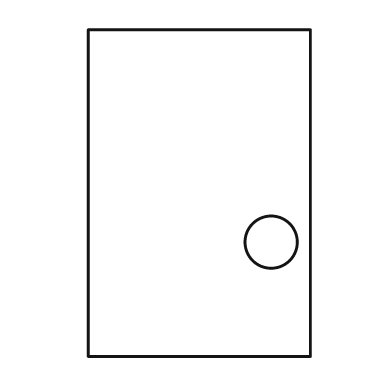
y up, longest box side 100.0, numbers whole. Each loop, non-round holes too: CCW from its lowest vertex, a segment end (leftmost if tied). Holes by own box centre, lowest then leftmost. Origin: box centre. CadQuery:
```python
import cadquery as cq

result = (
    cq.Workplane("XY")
    .moveTo(-34.0, -50.0)
    .lineTo(34.0, -50.0)
    .lineTo(34.0, 50.0)
    .lineTo(-34.0, 50.0)
    .close()
    .moveTo(22.0, -15.0)
    .circle(8.0)
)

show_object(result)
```